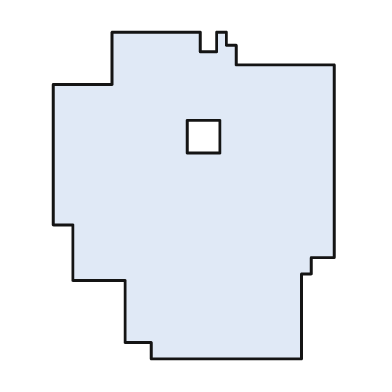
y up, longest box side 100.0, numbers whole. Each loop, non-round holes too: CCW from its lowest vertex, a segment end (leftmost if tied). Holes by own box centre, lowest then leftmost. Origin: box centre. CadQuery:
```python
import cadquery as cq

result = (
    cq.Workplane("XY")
    .moveTo(-13.0, -50.0)
    .lineTo(33.0, -50.0)
    .lineTo(33.0, -24.0)
    .lineTo(36.0, -24.0)
    .lineTo(36.0, -19.0)
    .lineTo(43.0, -19.0)
    .lineTo(43.0, 40.0)
    .lineTo(13.0, 40.0)
    .lineTo(13.0, 46.0)
    .lineTo(10.0, 46.0)
    .lineTo(10.0, 50.0)
    .lineTo(7.0, 50.0)
    .lineTo(7.0, 44.0)
    .lineTo(2.0, 44.0)
    .lineTo(2.0, 50.0)
    .lineTo(-25.0, 50.0)
    .lineTo(-25.0, 34.0)
    .lineTo(-43.0, 34.0)
    .lineTo(-43.0, -9.0)
    .lineTo(-37.0, -9.0)
    .lineTo(-37.0, -26.0)
    .lineTo(-21.0, -26.0)
    .lineTo(-21.0, -45.0)
    .lineTo(-13.0, -45.0)
    .close()
    .moveTo(-2.0, 13.0)
    .lineTo(8.0, 13.0)
    .lineTo(8.0, 23.0)
    .lineTo(-2.0, 23.0)
    .close()
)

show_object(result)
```